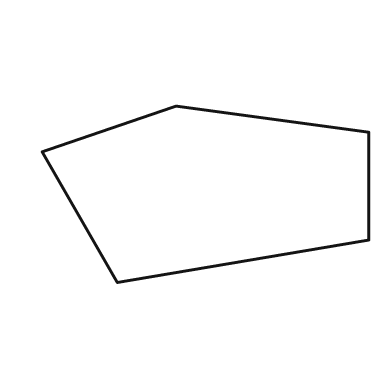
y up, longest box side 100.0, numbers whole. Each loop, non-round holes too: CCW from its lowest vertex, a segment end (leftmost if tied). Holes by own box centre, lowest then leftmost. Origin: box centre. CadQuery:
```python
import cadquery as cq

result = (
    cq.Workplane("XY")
    .moveTo(-27.0, -27.0)
    .lineTo(50.0, -14.0)
    .lineTo(50.0, 19.0)
    .lineTo(-9.0, 27.0)
    .lineTo(-50.0, 13.0)
    .close()
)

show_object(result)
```